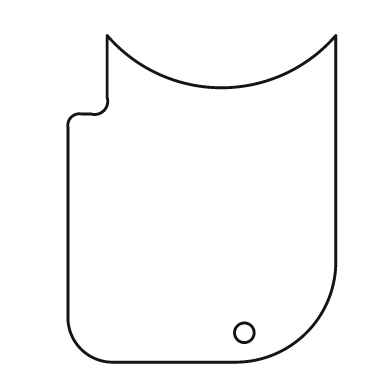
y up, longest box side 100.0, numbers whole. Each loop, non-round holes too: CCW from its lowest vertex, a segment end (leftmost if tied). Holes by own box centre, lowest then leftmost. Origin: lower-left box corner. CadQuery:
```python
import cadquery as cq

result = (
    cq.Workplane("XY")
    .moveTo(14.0, 0.0)
    .lineTo(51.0, 0.0)
    .threePointArc((73.0, 9.0), (82.0, 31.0))
    .lineTo(82.0, 100.0)
    .threePointArc((47.0, 84.0), (12.0, 100.0))
    .lineTo(12.0, 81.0)
    .threePointArc((11.0, 77.0), (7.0, 76.0))
    .lineTo(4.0, 76.0)
    .threePointArc((1.0, 75.0), (0.0, 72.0))
    .lineTo(0.0, 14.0)
    .threePointArc((4.0, 4.0), (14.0, 0.0))
    .close()
    .moveTo(54.0, 9.0)
    .circle(3.0)
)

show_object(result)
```